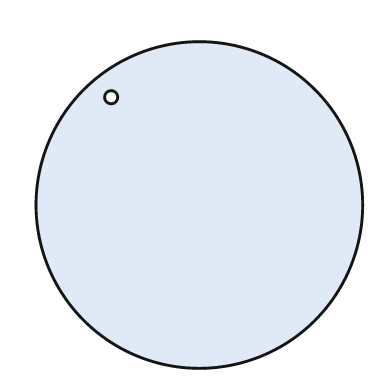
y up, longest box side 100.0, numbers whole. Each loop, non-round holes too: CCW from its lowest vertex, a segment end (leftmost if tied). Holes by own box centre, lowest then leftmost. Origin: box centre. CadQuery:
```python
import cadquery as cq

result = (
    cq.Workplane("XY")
    .moveTo(0.0, 0.0)
    .circle(50.0)
    .moveTo(-27.0, 33.0)
    .circle(2.0)
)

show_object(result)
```